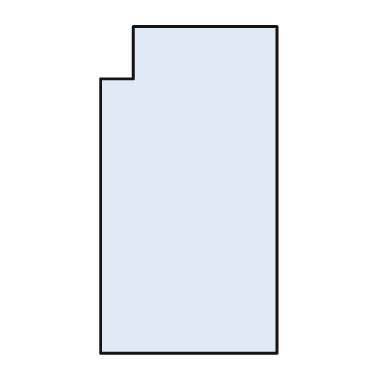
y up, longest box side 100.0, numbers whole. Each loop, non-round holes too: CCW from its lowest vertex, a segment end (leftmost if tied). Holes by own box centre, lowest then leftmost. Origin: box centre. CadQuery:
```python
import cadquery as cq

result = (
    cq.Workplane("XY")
    .moveTo(-27.0, -50.0)
    .lineTo(27.0, -50.0)
    .lineTo(27.0, 50.0)
    .lineTo(-17.0, 50.0)
    .lineTo(-17.0, 34.0)
    .lineTo(-27.0, 34.0)
    .close()
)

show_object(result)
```